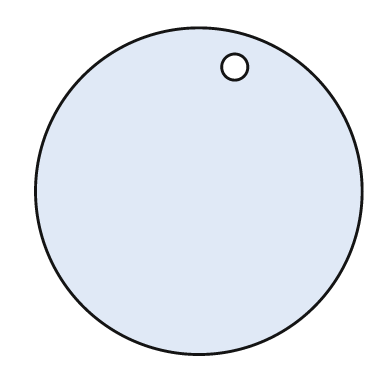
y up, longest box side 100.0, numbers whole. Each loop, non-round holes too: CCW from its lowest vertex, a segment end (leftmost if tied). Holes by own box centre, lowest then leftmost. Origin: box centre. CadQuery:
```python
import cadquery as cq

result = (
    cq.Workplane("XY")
    .moveTo(0.0, 0.0)
    .circle(50.0)
    .moveTo(11.0, 38.0)
    .circle(4.0)
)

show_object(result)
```